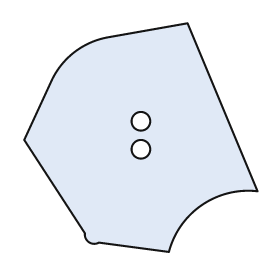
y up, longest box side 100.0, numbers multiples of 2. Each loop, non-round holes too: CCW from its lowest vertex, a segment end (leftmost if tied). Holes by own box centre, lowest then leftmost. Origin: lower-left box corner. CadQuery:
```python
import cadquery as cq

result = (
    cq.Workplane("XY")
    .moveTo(62.0, 0.0)
    .threePointArc((76.0, 20.0), (100.0, 26.0))
    .lineTo(70.0, 98.0)
    .lineTo(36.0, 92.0)
    .threePointArc((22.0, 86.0), (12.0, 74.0))
    .lineTo(0.0, 48.0)
    .lineTo(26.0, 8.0)
    .threePointArc((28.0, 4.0), (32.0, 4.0))
    .close()
    .moveTo(50.0, 44.0)
    .circle(4.0)
    .moveTo(50.0, 56.0)
    .circle(4.0)
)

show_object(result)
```